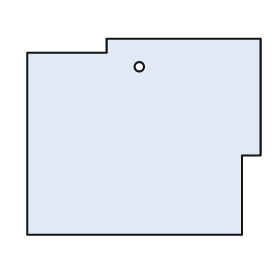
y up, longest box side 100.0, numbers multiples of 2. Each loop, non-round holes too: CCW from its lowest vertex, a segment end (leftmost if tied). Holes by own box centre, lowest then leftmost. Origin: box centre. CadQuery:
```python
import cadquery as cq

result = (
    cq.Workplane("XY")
    .moveTo(-50.0, -42.0)
    .lineTo(42.0, -42.0)
    .lineTo(42.0, -8.0)
    .lineTo(50.0, -8.0)
    .lineTo(50.0, 42.0)
    .lineTo(-16.0, 42.0)
    .lineTo(-16.0, 36.0)
    .lineTo(-50.0, 36.0)
    .close()
    .moveTo(-2.0, 30.0)
    .circle(2.0)
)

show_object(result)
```